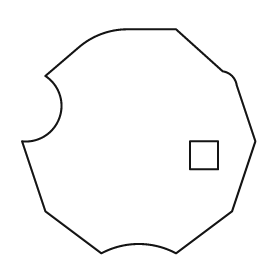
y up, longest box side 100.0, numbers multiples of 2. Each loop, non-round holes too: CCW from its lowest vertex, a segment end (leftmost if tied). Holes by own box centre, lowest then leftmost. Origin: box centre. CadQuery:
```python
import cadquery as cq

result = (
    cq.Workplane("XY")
    .moveTo(-16.0, -48.0)
    .threePointArc((0.0, -44.0), (16.0, -48.0))
    .lineTo(40.0, -30.0)
    .lineTo(50.0, 0.0)
    .lineTo(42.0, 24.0)
    .threePointArc((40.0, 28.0), (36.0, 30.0))
    .lineTo(16.0, 48.0)
    .lineTo(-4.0, 48.0)
    .threePointArc((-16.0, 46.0), (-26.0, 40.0))
    .lineTo(-40.0, 28.0)
    .threePointArc((-34.0, 10.0), (-50.0, 0.0))
    .lineTo(-40.0, -30.0)
    .close()
    .moveTo(22.0, -12.0)
    .lineTo(34.0, -12.0)
    .lineTo(34.0, 0.0)
    .lineTo(22.0, 0.0)
    .close()
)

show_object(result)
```